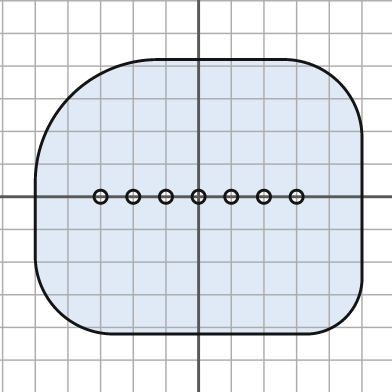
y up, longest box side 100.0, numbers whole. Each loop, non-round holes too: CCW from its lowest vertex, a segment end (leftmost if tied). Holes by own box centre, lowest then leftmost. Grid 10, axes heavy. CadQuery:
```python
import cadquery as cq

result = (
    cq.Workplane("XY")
    .moveTo(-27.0, -42.0)
    .lineTo(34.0, -42.0)
    .threePointArc((45.0, -37.0), (50.0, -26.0))
    .lineTo(50.0, 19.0)
    .threePointArc((43.0, 35.0), (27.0, 42.0))
    .lineTo(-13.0, 42.0)
    .threePointArc((-39.0, 31.0), (-50.0, 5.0))
    .lineTo(-50.0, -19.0)
    .threePointArc((-43.0, -35.0), (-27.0, -42.0))
    .close()
    .moveTo(-30.0, 0.0)
    .circle(2.0)
    .moveTo(-20.0, 0.0)
    .circle(2.0)
    .moveTo(-10.0, 0.0)
    .circle(2.0)
    .moveTo(0.0, 0.0)
    .circle(2.0)
    .moveTo(10.0, 0.0)
    .circle(2.0)
    .moveTo(20.0, 0.0)
    .circle(2.0)
    .moveTo(30.0, 0.0)
    .circle(2.0)
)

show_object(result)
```